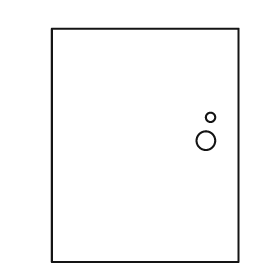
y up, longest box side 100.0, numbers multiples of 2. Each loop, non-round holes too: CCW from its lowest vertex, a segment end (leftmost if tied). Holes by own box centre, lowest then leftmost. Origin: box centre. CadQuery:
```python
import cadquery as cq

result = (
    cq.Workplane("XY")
    .moveTo(-40.0, -50.0)
    .lineTo(40.0, -50.0)
    .lineTo(40.0, 50.0)
    .lineTo(-40.0, 50.0)
    .close()
    .moveTo(26.0, 2.0)
    .circle(4.0)
    .moveTo(28.0, 12.0)
    .circle(2.0)
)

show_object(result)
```